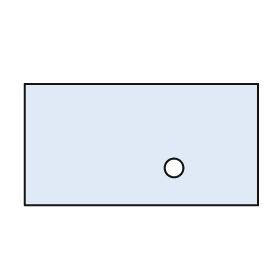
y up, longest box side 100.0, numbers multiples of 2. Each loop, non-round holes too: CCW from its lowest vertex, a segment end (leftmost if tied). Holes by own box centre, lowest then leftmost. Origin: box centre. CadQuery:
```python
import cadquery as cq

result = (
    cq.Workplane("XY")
    .moveTo(-50.0, -26.0)
    .lineTo(50.0, -26.0)
    .lineTo(50.0, 26.0)
    .lineTo(-50.0, 26.0)
    .close()
    .moveTo(14.0, -10.0)
    .circle(4.0)
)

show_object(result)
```